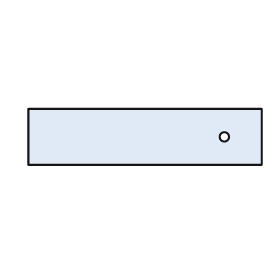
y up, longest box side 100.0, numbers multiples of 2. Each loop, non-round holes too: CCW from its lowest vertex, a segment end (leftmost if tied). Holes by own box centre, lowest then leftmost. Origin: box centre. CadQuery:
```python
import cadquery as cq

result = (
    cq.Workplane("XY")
    .moveTo(-50.0, -12.0)
    .lineTo(50.0, -12.0)
    .lineTo(50.0, 12.0)
    .lineTo(-50.0, 12.0)
    .close()
    .moveTo(34.0, 0.0)
    .circle(2.0)
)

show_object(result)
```